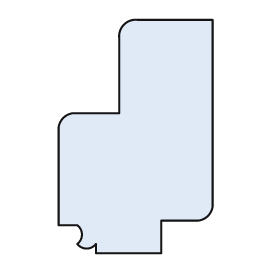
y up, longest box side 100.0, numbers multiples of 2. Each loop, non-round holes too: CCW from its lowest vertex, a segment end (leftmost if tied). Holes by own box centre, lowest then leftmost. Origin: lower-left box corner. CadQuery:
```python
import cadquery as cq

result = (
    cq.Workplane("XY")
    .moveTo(16.0, 0.0)
    .lineTo(44.0, 0.0)
    .lineTo(44.0, 14.0)
    .lineTo(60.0, 14.0)
    .threePointArc((64.0, 16.0), (66.0, 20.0))
    .lineTo(66.0, 100.0)
    .lineTo(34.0, 100.0)
    .threePointArc((28.0, 98.0), (26.0, 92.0))
    .lineTo(26.0, 60.0)
    .lineTo(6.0, 60.0)
    .threePointArc((2.0, 58.0), (0.0, 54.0))
    .lineTo(0.0, 12.0)
    .lineTo(8.0, 12.0)
    .threePointArc((10.0, 8.0), (8.0, 4.0))
    .threePointArc((12.0, 2.0), (16.0, 4.0))
    .close()
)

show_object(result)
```